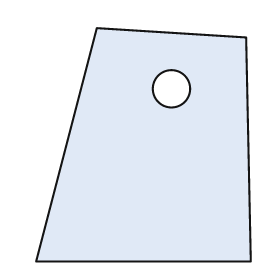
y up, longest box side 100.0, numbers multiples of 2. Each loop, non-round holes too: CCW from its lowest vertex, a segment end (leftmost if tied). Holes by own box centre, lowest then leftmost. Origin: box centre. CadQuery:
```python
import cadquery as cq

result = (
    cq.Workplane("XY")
    .moveTo(-46.0, -50.0)
    .lineTo(46.0, -50.0)
    .lineTo(44.0, 46.0)
    .lineTo(-20.0, 50.0)
    .close()
    .moveTo(12.0, 24.0)
    .circle(8.0)
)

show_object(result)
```